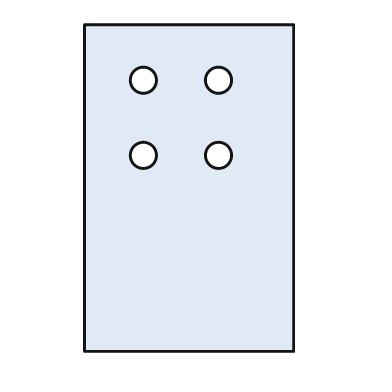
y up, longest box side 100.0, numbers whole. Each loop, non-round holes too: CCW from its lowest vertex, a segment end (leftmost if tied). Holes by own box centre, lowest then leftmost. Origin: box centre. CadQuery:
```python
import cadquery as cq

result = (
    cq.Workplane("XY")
    .moveTo(-32.0, -50.0)
    .lineTo(32.0, -50.0)
    .lineTo(32.0, 50.0)
    .lineTo(-32.0, 50.0)
    .close()
    .moveTo(-14.0, 10.0)
    .circle(4.0)
    .moveTo(9.0, 10.0)
    .circle(4.0)
    .moveTo(-14.0, 33.0)
    .circle(4.0)
    .moveTo(9.0, 33.0)
    .circle(4.0)
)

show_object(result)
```